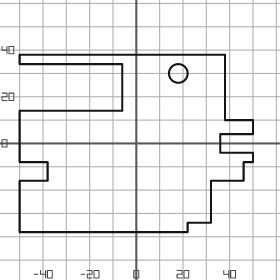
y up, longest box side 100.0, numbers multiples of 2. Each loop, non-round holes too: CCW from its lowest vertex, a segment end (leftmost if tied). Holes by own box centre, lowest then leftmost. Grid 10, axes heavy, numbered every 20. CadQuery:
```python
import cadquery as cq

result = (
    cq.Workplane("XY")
    .moveTo(-50.0, -38.0)
    .lineTo(22.0, -38.0)
    .lineTo(22.0, -34.0)
    .lineTo(32.0, -34.0)
    .lineTo(32.0, -16.0)
    .lineTo(46.0, -16.0)
    .lineTo(46.0, -8.0)
    .lineTo(50.0, -8.0)
    .lineTo(50.0, -4.0)
    .lineTo(36.0, -4.0)
    .lineTo(36.0, 4.0)
    .lineTo(50.0, 4.0)
    .lineTo(50.0, 10.0)
    .lineTo(38.0, 10.0)
    .lineTo(38.0, 38.0)
    .lineTo(-50.0, 38.0)
    .lineTo(-50.0, 34.0)
    .lineTo(-6.0, 34.0)
    .lineTo(-6.0, 14.0)
    .lineTo(-50.0, 14.0)
    .lineTo(-50.0, -8.0)
    .lineTo(-38.0, -8.0)
    .lineTo(-38.0, -16.0)
    .lineTo(-50.0, -16.0)
    .close()
    .moveTo(18.0, 30.0)
    .circle(4.0)
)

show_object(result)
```